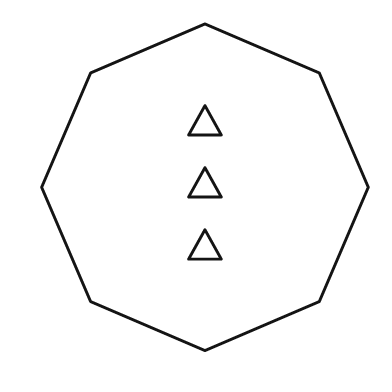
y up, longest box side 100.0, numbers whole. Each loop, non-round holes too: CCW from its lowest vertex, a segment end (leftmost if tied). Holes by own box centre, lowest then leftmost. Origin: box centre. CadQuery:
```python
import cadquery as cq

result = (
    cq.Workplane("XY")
    .moveTo(0.0, -50.0)
    .lineTo(35.0, -35.0)
    .lineTo(50.0, 0.0)
    .lineTo(35.0, 35.0)
    .lineTo(0.0, 50.0)
    .lineTo(-35.0, 35.0)
    .lineTo(-50.0, 0.0)
    .lineTo(-35.0, -35.0)
    .close()
    .moveTo(-5.0, -22.0)
    .lineTo(5.0, -22.0)
    .lineTo(0.0, -13.0)
    .close()
    .moveTo(-5.0, -3.0)
    .lineTo(5.0, -3.0)
    .lineTo(0.0, 6.0)
    .close()
    .moveTo(-5.0, 16.0)
    .lineTo(5.0, 16.0)
    .lineTo(0.0, 25.0)
    .close()
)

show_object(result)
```